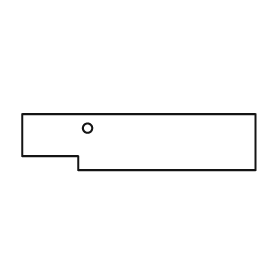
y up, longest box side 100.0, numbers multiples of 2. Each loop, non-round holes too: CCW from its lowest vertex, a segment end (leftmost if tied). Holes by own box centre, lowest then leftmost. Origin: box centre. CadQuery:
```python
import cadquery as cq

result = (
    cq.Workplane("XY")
    .moveTo(-26.0, -12.0)
    .lineTo(50.0, -12.0)
    .lineTo(50.0, 12.0)
    .lineTo(-50.0, 12.0)
    .lineTo(-50.0, -6.0)
    .lineTo(-26.0, -6.0)
    .close()
    .moveTo(-22.0, 6.0)
    .circle(2.0)
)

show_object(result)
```